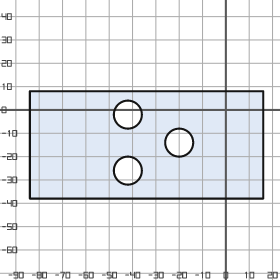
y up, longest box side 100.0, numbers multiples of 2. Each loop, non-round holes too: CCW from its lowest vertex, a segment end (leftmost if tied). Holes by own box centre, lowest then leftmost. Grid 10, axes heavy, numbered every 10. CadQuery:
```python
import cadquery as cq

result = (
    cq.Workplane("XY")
    .moveTo(-84.0, -38.0)
    .lineTo(16.0, -38.0)
    .lineTo(16.0, 8.0)
    .lineTo(-84.0, 8.0)
    .close()
    .moveTo(-42.0, -26.0)
    .circle(6.0)
    .moveTo(-20.0, -14.0)
    .circle(6.0)
    .moveTo(-42.0, -2.0)
    .circle(6.0)
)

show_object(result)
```